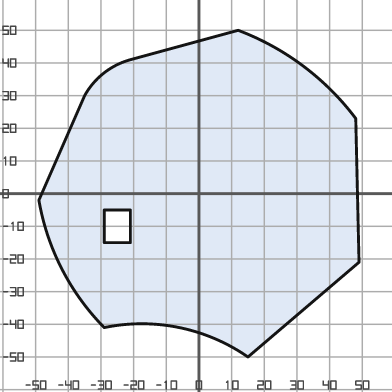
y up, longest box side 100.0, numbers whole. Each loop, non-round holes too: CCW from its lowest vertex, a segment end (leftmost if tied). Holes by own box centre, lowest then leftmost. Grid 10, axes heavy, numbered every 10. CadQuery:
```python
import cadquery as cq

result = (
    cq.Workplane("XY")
    .moveTo(15.0, -50.0)
    .lineTo(49.0, -21.0)
    .lineTo(48.0, 23.0)
    .threePointArc((32.0, 39.0), (12.0, 50.0))
    .lineTo(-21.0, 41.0)
    .threePointArc((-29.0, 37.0), (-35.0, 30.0))
    .lineTo(-49.0, -2.0)
    .threePointArc((-42.0, -23.0), (-29.0, -41.0))
    .threePointArc((-6.0, -41.0), (15.0, -50.0))
    .close()
    .moveTo(-29.0, -15.0)
    .lineTo(-21.0, -15.0)
    .lineTo(-21.0, -5.0)
    .lineTo(-29.0, -5.0)
    .close()
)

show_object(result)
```